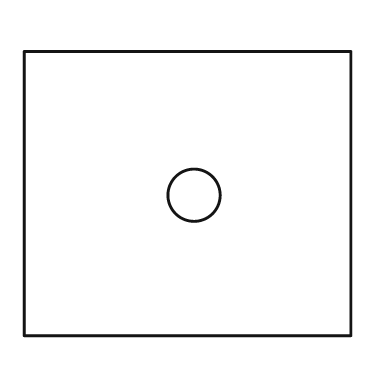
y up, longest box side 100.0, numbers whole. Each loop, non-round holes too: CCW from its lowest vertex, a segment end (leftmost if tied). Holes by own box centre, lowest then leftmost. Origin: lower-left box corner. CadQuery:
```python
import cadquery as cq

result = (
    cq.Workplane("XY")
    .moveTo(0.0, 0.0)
    .lineTo(100.0, 0.0)
    .lineTo(100.0, 87.0)
    .lineTo(0.0, 87.0)
    .close()
    .moveTo(52.0, 43.0)
    .circle(8.0)
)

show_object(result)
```